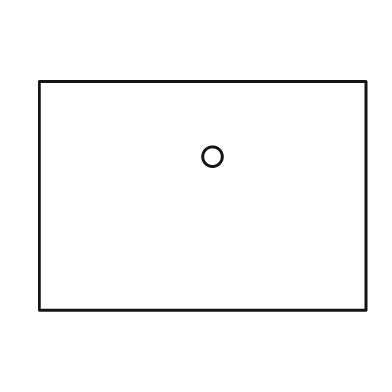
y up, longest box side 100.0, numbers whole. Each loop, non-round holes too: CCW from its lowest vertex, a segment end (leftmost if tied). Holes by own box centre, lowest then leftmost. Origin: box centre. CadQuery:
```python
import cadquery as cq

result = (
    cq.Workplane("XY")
    .moveTo(-50.0, -35.0)
    .lineTo(50.0, -35.0)
    .lineTo(50.0, 35.0)
    .lineTo(-50.0, 35.0)
    .close()
    .moveTo(3.0, 12.0)
    .circle(3.0)
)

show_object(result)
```